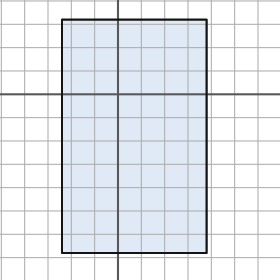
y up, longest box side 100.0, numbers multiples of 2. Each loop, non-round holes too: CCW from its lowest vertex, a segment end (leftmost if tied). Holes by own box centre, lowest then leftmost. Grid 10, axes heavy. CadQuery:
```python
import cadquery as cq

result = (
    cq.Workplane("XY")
    .moveTo(-24.0, -68.0)
    .lineTo(38.0, -68.0)
    .lineTo(38.0, 32.0)
    .lineTo(-24.0, 32.0)
    .close()
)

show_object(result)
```